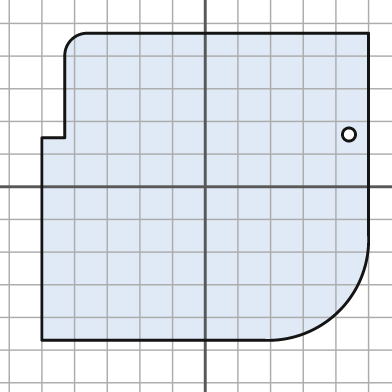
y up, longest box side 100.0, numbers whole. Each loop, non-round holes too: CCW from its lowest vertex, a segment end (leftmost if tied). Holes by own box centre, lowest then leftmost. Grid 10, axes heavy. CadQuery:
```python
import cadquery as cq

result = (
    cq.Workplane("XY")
    .moveTo(-50.0, -47.0)
    .lineTo(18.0, -47.0)
    .threePointArc((41.0, -38.0), (50.0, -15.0))
    .lineTo(50.0, 47.0)
    .lineTo(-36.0, 47.0)
    .threePointArc((-41.0, 45.0), (-43.0, 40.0))
    .lineTo(-43.0, 15.0)
    .lineTo(-50.0, 15.0)
    .close()
    .moveTo(44.0, 16.0)
    .circle(2.0)
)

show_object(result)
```